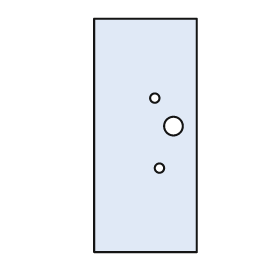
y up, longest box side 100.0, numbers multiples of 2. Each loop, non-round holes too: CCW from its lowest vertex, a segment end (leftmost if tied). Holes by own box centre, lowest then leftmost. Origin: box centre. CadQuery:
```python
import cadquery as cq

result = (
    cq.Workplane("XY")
    .moveTo(-22.0, -50.0)
    .lineTo(22.0, -50.0)
    .lineTo(22.0, 50.0)
    .lineTo(-22.0, 50.0)
    .close()
    .moveTo(6.0, -14.0)
    .circle(2.0)
    .moveTo(12.0, 4.0)
    .circle(4.0)
    .moveTo(4.0, 16.0)
    .circle(2.0)
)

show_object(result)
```